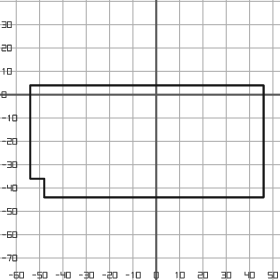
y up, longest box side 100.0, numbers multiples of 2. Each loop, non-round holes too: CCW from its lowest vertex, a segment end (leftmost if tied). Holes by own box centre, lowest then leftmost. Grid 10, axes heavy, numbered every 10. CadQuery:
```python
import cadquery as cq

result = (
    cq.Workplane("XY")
    .moveTo(-48.0, -44.0)
    .lineTo(46.0, -44.0)
    .lineTo(46.0, 4.0)
    .lineTo(-54.0, 4.0)
    .lineTo(-54.0, -36.0)
    .lineTo(-48.0, -36.0)
    .close()
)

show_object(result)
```